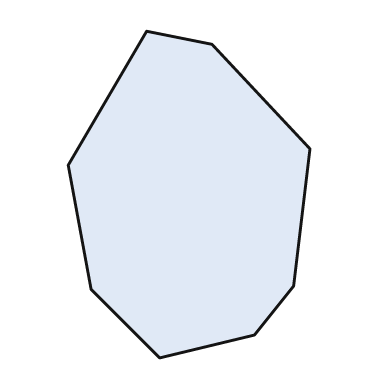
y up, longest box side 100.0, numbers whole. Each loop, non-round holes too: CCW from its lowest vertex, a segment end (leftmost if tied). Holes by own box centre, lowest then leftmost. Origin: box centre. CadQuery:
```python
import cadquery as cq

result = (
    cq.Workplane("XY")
    .moveTo(-9.0, -50.0)
    .lineTo(20.0, -43.0)
    .lineTo(32.0, -28.0)
    .lineTo(37.0, 14.0)
    .lineTo(7.0, 46.0)
    .lineTo(-13.0, 50.0)
    .lineTo(-37.0, 9.0)
    .lineTo(-30.0, -29.0)
    .close()
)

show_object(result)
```